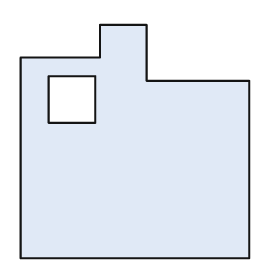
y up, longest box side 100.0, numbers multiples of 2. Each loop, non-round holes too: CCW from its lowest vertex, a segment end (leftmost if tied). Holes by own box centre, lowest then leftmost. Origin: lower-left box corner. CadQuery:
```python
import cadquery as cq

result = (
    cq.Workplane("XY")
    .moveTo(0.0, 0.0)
    .lineTo(98.0, 0.0)
    .lineTo(98.0, 76.0)
    .lineTo(54.0, 76.0)
    .lineTo(54.0, 100.0)
    .lineTo(34.0, 100.0)
    .lineTo(34.0, 86.0)
    .lineTo(0.0, 86.0)
    .close()
    .moveTo(12.0, 58.0)
    .lineTo(32.0, 58.0)
    .lineTo(32.0, 78.0)
    .lineTo(12.0, 78.0)
    .close()
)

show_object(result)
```